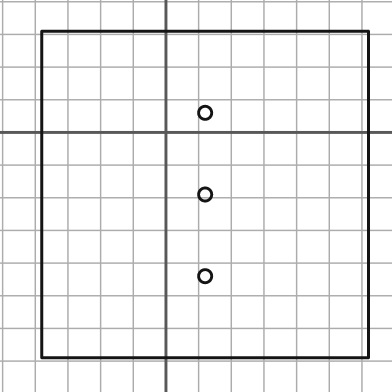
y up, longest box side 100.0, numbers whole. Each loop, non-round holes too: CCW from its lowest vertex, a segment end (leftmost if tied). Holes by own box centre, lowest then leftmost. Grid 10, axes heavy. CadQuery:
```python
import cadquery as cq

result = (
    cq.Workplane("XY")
    .moveTo(-38.0, -69.0)
    .lineTo(62.0, -69.0)
    .lineTo(62.0, 31.0)
    .lineTo(-38.0, 31.0)
    .close()
    .moveTo(12.0, -44.0)
    .circle(2.0)
    .moveTo(12.0, -19.0)
    .circle(2.0)
    .moveTo(12.0, 6.0)
    .circle(2.0)
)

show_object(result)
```